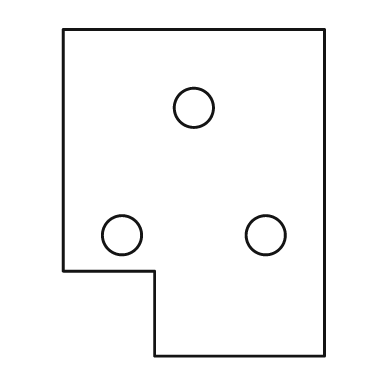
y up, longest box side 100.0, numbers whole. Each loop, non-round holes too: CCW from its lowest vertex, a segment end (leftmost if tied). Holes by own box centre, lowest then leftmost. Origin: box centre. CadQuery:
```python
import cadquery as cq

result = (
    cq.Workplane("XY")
    .moveTo(-12.0, -50.0)
    .lineTo(40.0, -50.0)
    .lineTo(40.0, 50.0)
    .lineTo(-40.0, 50.0)
    .lineTo(-40.0, -24.0)
    .lineTo(-12.0, -24.0)
    .close()
    .moveTo(-22.0, -13.0)
    .circle(6.0)
    .moveTo(22.0, -13.0)
    .circle(6.0)
    .moveTo(0.0, 26.0)
    .circle(6.0)
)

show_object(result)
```